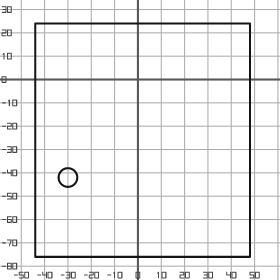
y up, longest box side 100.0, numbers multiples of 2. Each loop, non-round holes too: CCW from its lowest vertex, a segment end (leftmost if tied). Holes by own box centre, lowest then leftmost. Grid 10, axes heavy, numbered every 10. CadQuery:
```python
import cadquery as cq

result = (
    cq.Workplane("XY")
    .moveTo(-44.0, -76.0)
    .lineTo(48.0, -76.0)
    .lineTo(48.0, 24.0)
    .lineTo(-44.0, 24.0)
    .close()
    .moveTo(-30.0, -42.0)
    .circle(4.0)
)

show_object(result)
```